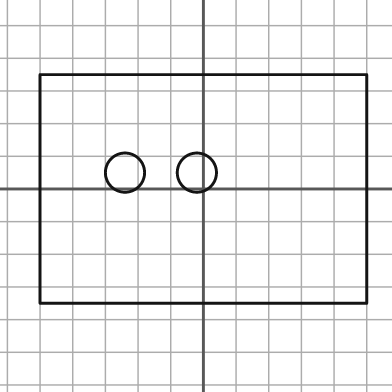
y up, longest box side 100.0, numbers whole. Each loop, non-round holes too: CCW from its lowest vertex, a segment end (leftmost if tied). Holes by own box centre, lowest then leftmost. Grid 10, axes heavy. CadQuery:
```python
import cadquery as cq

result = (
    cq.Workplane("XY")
    .moveTo(-50.0, -35.0)
    .lineTo(50.0, -35.0)
    .lineTo(50.0, 35.0)
    .lineTo(-50.0, 35.0)
    .close()
    .moveTo(-24.0, 5.0)
    .circle(6.0)
    .moveTo(-2.0, 5.0)
    .circle(6.0)
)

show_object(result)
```